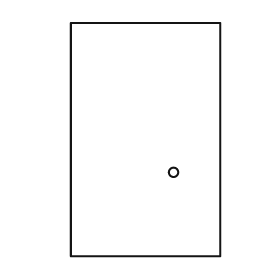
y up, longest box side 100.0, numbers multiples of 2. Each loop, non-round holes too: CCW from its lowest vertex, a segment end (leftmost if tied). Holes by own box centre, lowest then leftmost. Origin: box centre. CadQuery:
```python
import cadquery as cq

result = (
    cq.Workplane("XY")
    .moveTo(-32.0, -50.0)
    .lineTo(32.0, -50.0)
    .lineTo(32.0, 50.0)
    .lineTo(-32.0, 50.0)
    .close()
    .moveTo(12.0, -14.0)
    .circle(2.0)
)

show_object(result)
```